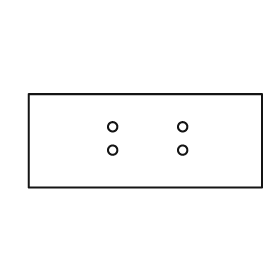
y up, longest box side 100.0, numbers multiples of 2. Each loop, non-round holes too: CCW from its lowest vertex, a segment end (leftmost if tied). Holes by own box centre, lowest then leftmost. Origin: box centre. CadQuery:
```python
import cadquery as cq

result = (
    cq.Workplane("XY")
    .moveTo(-50.0, -20.0)
    .lineTo(50.0, -20.0)
    .lineTo(50.0, 20.0)
    .lineTo(-50.0, 20.0)
    .close()
    .moveTo(-14.0, -4.0)
    .circle(2.0)
    .moveTo(16.0, -4.0)
    .circle(2.0)
    .moveTo(-14.0, 6.0)
    .circle(2.0)
    .moveTo(16.0, 6.0)
    .circle(2.0)
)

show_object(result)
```